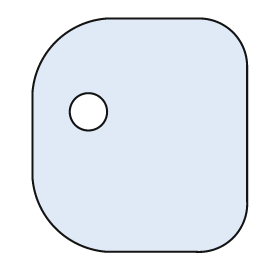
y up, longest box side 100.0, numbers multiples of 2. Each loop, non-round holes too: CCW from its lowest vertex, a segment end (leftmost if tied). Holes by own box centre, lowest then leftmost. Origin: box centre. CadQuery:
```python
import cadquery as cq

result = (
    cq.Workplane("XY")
    .moveTo(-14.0, -50.0)
    .lineTo(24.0, -50.0)
    .threePointArc((40.0, -44.0), (46.0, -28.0))
    .lineTo(46.0, 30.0)
    .threePointArc((40.0, 44.0), (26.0, 50.0))
    .lineTo(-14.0, 50.0)
    .threePointArc((-36.0, 40.0), (-46.0, 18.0))
    .lineTo(-46.0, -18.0)
    .threePointArc((-36.0, -40.0), (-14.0, -50.0))
    .close()
    .moveTo(-22.0, 10.0)
    .circle(8.0)
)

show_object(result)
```